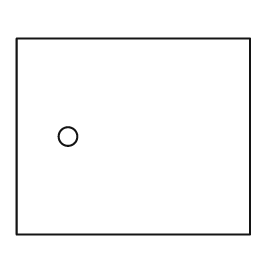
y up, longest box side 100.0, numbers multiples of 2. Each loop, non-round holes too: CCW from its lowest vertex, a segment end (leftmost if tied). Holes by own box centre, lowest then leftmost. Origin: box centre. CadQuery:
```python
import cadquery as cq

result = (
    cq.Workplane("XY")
    .moveTo(-50.0, -42.0)
    .lineTo(50.0, -42.0)
    .lineTo(50.0, 42.0)
    .lineTo(-50.0, 42.0)
    .close()
    .moveTo(-28.0, 0.0)
    .circle(4.0)
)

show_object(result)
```